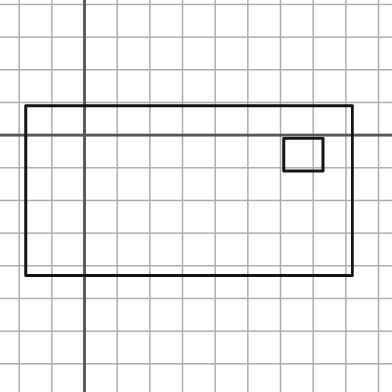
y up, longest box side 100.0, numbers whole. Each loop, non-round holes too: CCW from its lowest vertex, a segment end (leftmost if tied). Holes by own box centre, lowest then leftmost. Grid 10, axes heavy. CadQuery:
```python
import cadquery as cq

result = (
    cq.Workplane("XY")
    .moveTo(-18.0, -43.0)
    .lineTo(82.0, -43.0)
    .lineTo(82.0, 9.0)
    .lineTo(-18.0, 9.0)
    .close()
    .moveTo(61.0, -11.0)
    .lineTo(73.0, -11.0)
    .lineTo(73.0, -1.0)
    .lineTo(61.0, -1.0)
    .close()
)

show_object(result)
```